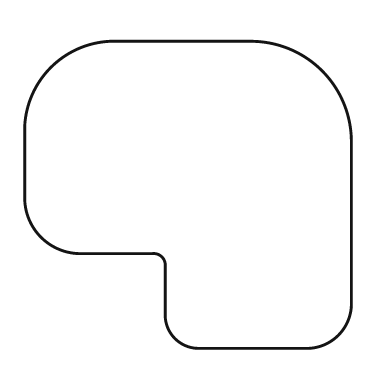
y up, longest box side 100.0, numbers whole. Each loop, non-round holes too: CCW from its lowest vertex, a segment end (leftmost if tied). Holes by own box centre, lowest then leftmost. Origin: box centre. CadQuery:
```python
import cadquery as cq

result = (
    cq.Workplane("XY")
    .moveTo(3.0, -47.0)
    .lineTo(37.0, -47.0)
    .threePointArc((46.0, -43.0), (50.0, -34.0))
    .lineTo(50.0, 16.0)
    .threePointArc((41.0, 38.0), (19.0, 47.0))
    .lineTo(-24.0, 47.0)
    .threePointArc((-42.0, 39.0), (-50.0, 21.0))
    .lineTo(-50.0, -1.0)
    .threePointArc((-45.0, -13.0), (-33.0, -18.0))
    .lineTo(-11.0, -18.0)
    .threePointArc((-8.0, -19.0), (-7.0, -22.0))
    .lineTo(-7.0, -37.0)
    .threePointArc((-4.0, -44.0), (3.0, -47.0))
    .close()
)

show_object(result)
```